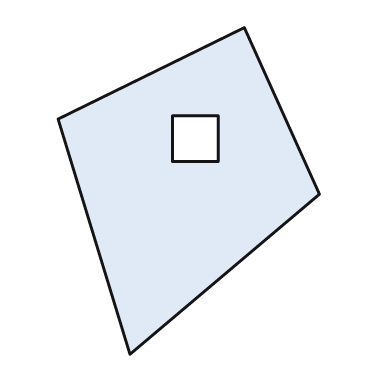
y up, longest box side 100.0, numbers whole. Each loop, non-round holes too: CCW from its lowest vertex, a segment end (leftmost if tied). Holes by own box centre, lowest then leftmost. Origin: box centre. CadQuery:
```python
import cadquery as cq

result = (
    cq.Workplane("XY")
    .moveTo(-18.0, -50.0)
    .lineTo(40.0, -1.0)
    .lineTo(17.0, 50.0)
    .lineTo(-40.0, 22.0)
    .close()
    .moveTo(-5.0, 9.0)
    .lineTo(9.0, 9.0)
    .lineTo(9.0, 23.0)
    .lineTo(-5.0, 23.0)
    .close()
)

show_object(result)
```